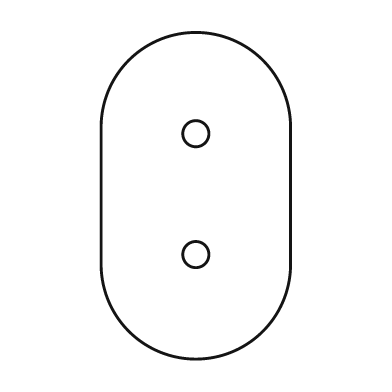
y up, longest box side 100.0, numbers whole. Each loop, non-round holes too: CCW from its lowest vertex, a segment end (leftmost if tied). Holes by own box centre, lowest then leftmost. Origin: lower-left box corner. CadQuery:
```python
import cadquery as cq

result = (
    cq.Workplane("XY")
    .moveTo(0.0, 29.0)
    .threePointArc((29.0, 0.0), (58.0, 29.0))
    .lineTo(58.0, 71.0)
    .threePointArc((29.0, 100.0), (0.0, 71.0))
    .close()
    .moveTo(29.0, 32.0)
    .circle(4.0)
    .moveTo(29.0, 69.0)
    .circle(4.0)
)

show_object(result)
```